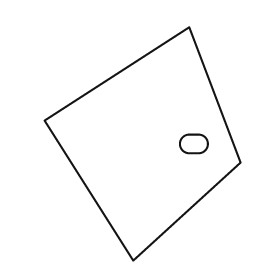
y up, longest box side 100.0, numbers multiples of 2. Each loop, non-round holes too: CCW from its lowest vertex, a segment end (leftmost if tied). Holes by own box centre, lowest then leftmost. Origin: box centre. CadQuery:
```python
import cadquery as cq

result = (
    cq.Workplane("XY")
    .moveTo(-4.0, -50.0)
    .lineTo(42.0, -8.0)
    .lineTo(20.0, 50.0)
    .lineTo(-42.0, 10.0)
    .close()
    .moveTo(20.0, -4.0)
    .lineTo(24.0, -4.0)
    .threePointArc((28.0, 0.0), (24.0, 4.0))
    .lineTo(20.0, 4.0)
    .threePointArc((16.0, 0.0), (20.0, -4.0))
    .close()
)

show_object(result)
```